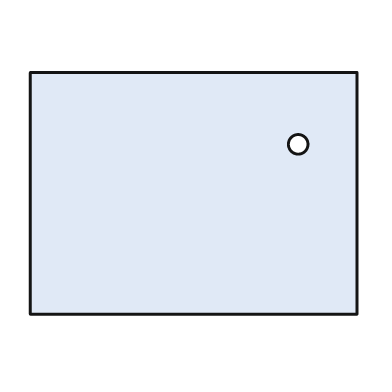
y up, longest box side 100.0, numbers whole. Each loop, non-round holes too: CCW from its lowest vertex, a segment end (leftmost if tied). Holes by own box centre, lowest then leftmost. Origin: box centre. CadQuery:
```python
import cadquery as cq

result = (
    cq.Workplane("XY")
    .moveTo(-50.0, -37.0)
    .lineTo(50.0, -37.0)
    .lineTo(50.0, 37.0)
    .lineTo(-50.0, 37.0)
    .close()
    .moveTo(32.0, 15.0)
    .circle(3.0)
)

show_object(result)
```